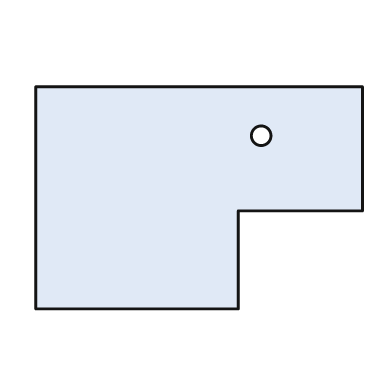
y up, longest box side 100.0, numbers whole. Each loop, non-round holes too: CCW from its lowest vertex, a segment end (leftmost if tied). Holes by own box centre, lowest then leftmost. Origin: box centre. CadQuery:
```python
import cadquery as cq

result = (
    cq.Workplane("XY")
    .moveTo(-50.0, -34.0)
    .lineTo(12.0, -34.0)
    .lineTo(12.0, -4.0)
    .lineTo(50.0, -4.0)
    .lineTo(50.0, 34.0)
    .lineTo(-50.0, 34.0)
    .close()
    .moveTo(19.0, 19.0)
    .circle(3.0)
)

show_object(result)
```